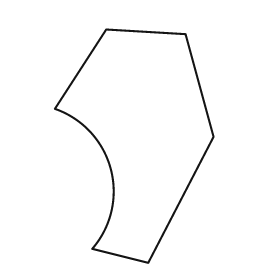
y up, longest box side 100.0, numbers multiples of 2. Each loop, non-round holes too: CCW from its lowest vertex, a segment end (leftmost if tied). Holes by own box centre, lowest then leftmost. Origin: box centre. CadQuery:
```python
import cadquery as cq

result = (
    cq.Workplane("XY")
    .moveTo(6.0, -50.0)
    .lineTo(34.0, 4.0)
    .lineTo(22.0, 48.0)
    .lineTo(-12.0, 50.0)
    .lineTo(-34.0, 16.0)
    .threePointArc((-10.0, -10.0), (-18.0, -44.0))
    .close()
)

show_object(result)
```